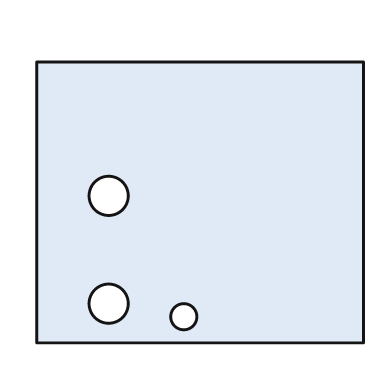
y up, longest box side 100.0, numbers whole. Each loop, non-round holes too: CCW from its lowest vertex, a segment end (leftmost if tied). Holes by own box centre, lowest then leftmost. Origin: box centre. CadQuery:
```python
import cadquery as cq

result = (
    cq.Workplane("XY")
    .moveTo(-50.0, -43.0)
    .lineTo(50.0, -43.0)
    .lineTo(50.0, 43.0)
    .lineTo(-50.0, 43.0)
    .close()
    .moveTo(-5.0, -35.0)
    .circle(4.0)
    .moveTo(-28.0, -31.0)
    .circle(6.0)
    .moveTo(-28.0, 2.0)
    .circle(6.0)
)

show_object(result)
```